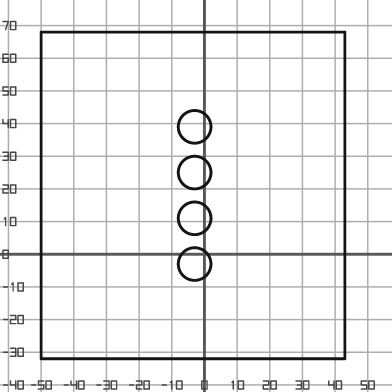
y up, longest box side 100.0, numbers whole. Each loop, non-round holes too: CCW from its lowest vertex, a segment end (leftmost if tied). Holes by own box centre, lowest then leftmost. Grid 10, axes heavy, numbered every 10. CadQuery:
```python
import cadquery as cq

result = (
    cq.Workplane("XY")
    .moveTo(-50.0, -32.0)
    .lineTo(43.0, -32.0)
    .lineTo(43.0, 68.0)
    .lineTo(-50.0, 68.0)
    .close()
    .moveTo(-3.0, -3.0)
    .circle(5.0)
    .moveTo(-3.0, 11.0)
    .circle(5.0)
    .moveTo(-3.0, 25.0)
    .circle(5.0)
    .moveTo(-3.0, 39.0)
    .circle(5.0)
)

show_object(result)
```